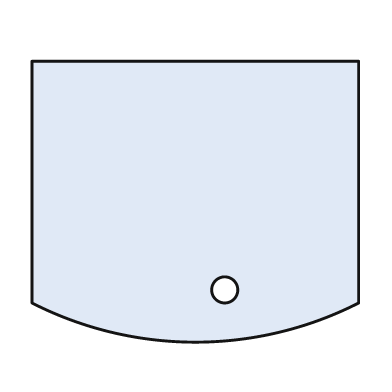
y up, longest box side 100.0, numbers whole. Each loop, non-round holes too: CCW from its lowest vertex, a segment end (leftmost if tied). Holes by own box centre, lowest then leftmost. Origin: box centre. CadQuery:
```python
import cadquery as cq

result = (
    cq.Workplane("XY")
    .moveTo(-50.0, -31.0)
    .threePointArc((0.0, -43.0), (50.0, -31.0))
    .lineTo(50.0, 43.0)
    .lineTo(-50.0, 43.0)
    .close()
    .moveTo(9.0, -27.0)
    .circle(4.0)
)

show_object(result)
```